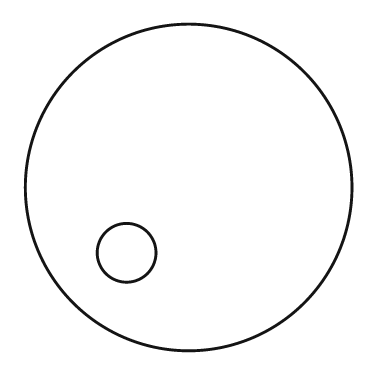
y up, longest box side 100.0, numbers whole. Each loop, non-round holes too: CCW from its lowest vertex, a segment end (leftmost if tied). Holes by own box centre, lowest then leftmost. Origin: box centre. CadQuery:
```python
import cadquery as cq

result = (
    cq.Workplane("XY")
    .moveTo(0.0, 0.0)
    .circle(50.0)
    .moveTo(-19.0, -20.0)
    .circle(9.0)
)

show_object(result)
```